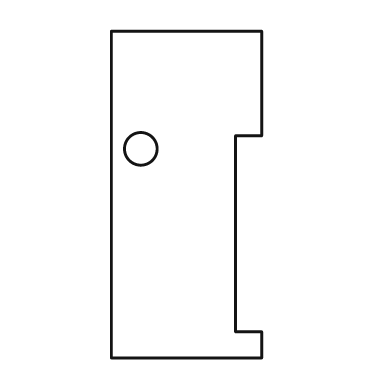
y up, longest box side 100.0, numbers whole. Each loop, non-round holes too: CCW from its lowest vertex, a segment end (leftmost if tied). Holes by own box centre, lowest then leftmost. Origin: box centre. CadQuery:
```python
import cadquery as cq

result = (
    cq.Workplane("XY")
    .moveTo(-23.0, -50.0)
    .lineTo(23.0, -50.0)
    .lineTo(23.0, -42.0)
    .lineTo(15.0, -42.0)
    .lineTo(15.0, 18.0)
    .lineTo(23.0, 18.0)
    .lineTo(23.0, 50.0)
    .lineTo(-23.0, 50.0)
    .close()
    .moveTo(-14.0, 14.0)
    .circle(5.0)
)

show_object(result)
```